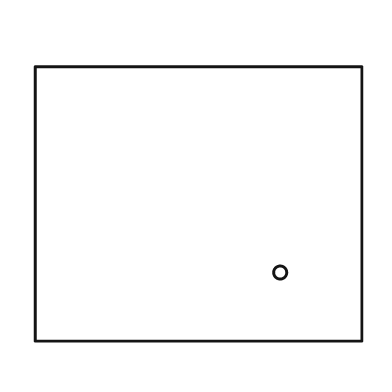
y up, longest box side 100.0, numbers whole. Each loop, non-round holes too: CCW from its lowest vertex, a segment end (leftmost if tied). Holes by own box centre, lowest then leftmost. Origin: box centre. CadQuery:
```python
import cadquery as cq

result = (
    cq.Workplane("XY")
    .moveTo(-50.0, -42.0)
    .lineTo(50.0, -42.0)
    .lineTo(50.0, 42.0)
    .lineTo(-50.0, 42.0)
    .close()
    .moveTo(25.0, -21.0)
    .circle(2.0)
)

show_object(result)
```